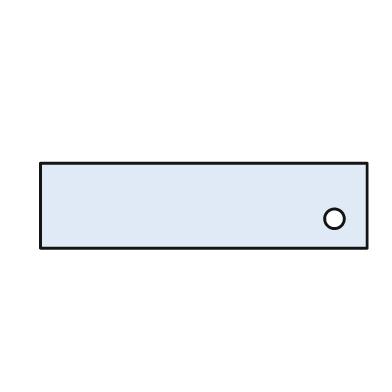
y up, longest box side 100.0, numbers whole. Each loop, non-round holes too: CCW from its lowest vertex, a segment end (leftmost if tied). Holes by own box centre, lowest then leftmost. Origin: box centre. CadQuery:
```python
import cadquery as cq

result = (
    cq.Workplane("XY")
    .moveTo(-50.0, -13.0)
    .lineTo(50.0, -13.0)
    .lineTo(50.0, 13.0)
    .lineTo(-50.0, 13.0)
    .close()
    .moveTo(40.0, -4.0)
    .circle(3.0)
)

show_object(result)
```